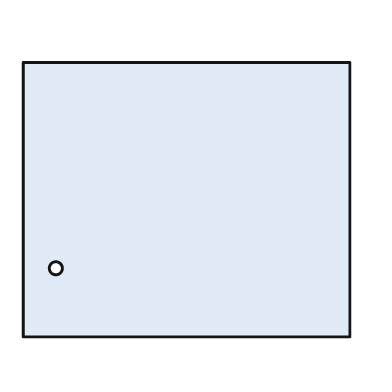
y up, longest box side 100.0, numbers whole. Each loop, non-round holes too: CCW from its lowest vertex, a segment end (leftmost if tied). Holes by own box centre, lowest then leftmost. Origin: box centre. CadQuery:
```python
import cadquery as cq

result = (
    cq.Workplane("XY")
    .moveTo(-50.0, -42.0)
    .lineTo(50.0, -42.0)
    .lineTo(50.0, 42.0)
    .lineTo(-50.0, 42.0)
    .close()
    .moveTo(-40.0, -21.0)
    .circle(2.0)
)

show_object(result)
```